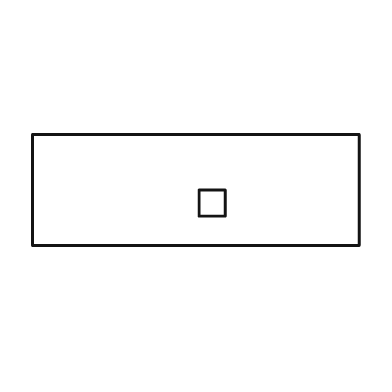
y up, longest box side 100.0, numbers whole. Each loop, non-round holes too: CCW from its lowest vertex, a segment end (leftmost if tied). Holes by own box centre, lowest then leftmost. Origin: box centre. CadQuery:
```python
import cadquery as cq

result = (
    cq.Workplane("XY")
    .moveTo(-50.0, -17.0)
    .lineTo(50.0, -17.0)
    .lineTo(50.0, 17.0)
    .lineTo(-50.0, 17.0)
    .close()
    .moveTo(1.0, -8.0)
    .lineTo(9.0, -8.0)
    .lineTo(9.0, 0.0)
    .lineTo(1.0, 0.0)
    .close()
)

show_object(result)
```